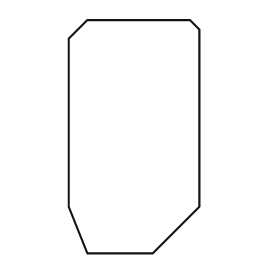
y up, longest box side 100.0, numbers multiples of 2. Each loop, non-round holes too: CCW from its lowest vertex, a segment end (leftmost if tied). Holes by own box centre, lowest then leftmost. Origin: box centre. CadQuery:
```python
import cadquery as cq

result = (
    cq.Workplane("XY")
    .moveTo(-20.0, -50.0)
    .lineTo(8.0, -50.0)
    .lineTo(28.0, -30.0)
    .lineTo(28.0, 46.0)
    .lineTo(24.0, 50.0)
    .lineTo(-20.0, 50.0)
    .lineTo(-28.0, 42.0)
    .lineTo(-28.0, -30.0)
    .close()
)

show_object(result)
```